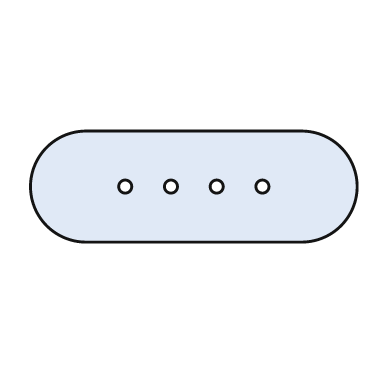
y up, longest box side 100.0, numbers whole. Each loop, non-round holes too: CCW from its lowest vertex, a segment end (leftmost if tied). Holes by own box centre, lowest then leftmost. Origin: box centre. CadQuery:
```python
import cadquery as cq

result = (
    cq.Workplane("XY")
    .moveTo(-33.0, -17.0)
    .lineTo(33.0, -17.0)
    .threePointArc((50.0, 0.0), (33.0, 17.0))
    .lineTo(-33.0, 17.0)
    .threePointArc((-50.0, 0.0), (-33.0, -17.0))
    .close()
    .moveTo(-21.0, 0.0)
    .circle(2.0)
    .moveTo(-7.0, 0.0)
    .circle(2.0)
    .moveTo(7.0, 0.0)
    .circle(2.0)
    .moveTo(21.0, 0.0)
    .circle(2.0)
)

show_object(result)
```